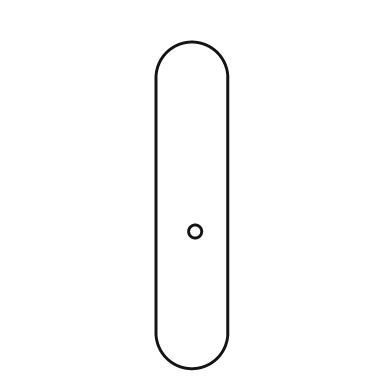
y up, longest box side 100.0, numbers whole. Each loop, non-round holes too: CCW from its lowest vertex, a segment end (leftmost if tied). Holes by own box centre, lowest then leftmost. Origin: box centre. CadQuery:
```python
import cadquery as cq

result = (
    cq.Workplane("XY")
    .moveTo(-11.0, -39.0)
    .threePointArc((0.0, -50.0), (11.0, -39.0))
    .lineTo(11.0, 39.0)
    .threePointArc((0.0, 50.0), (-11.0, 39.0))
    .close()
    .moveTo(1.0, -8.0)
    .circle(2.0)
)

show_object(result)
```